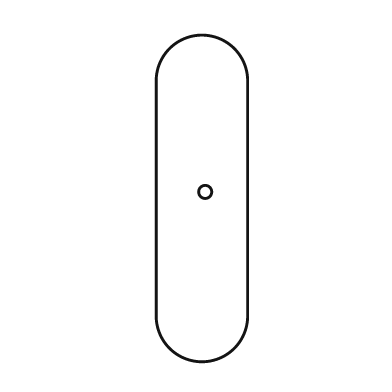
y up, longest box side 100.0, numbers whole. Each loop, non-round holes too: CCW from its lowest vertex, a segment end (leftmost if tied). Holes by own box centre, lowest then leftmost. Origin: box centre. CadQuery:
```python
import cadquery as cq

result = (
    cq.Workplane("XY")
    .moveTo(-14.0, -36.0)
    .threePointArc((0.0, -50.0), (14.0, -36.0))
    .lineTo(14.0, 36.0)
    .threePointArc((0.0, 50.0), (-14.0, 36.0))
    .close()
    .moveTo(1.0, 2.0)
    .circle(2.0)
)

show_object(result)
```